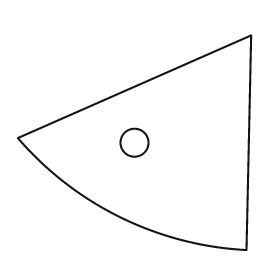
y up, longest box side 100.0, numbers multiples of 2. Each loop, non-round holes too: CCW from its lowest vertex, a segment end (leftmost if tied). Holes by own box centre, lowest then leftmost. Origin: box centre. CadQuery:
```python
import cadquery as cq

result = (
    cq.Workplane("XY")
    .moveTo(48.0, -46.0)
    .lineTo(50.0, 46.0)
    .lineTo(-50.0, 2.0)
    .threePointArc((-6.0, -32.0), (48.0, -46.0))
    .close()
    .moveTo(0.0, 0.0)
    .circle(6.0)
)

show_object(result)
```